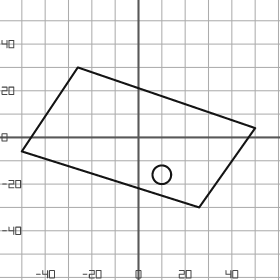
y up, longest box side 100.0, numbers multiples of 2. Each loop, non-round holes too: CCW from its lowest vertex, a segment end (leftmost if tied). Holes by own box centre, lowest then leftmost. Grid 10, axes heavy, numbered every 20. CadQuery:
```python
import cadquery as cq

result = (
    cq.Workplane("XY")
    .moveTo(26.0, -30.0)
    .lineTo(50.0, 4.0)
    .lineTo(-26.0, 30.0)
    .lineTo(-50.0, -6.0)
    .close()
    .moveTo(10.0, -16.0)
    .circle(4.0)
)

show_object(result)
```